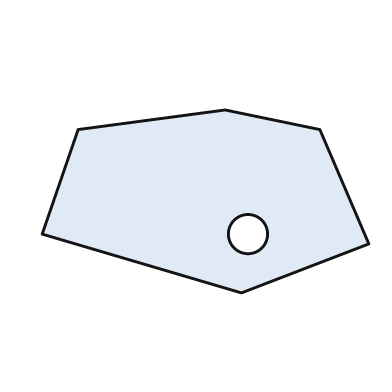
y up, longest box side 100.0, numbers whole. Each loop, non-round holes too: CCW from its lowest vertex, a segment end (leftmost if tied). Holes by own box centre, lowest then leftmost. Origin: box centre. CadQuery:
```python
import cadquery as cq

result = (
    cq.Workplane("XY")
    .moveTo(11.0, -28.0)
    .lineTo(50.0, -13.0)
    .lineTo(35.0, 22.0)
    .lineTo(6.0, 28.0)
    .lineTo(-39.0, 22.0)
    .lineTo(-50.0, -10.0)
    .close()
    .moveTo(13.0, -10.0)
    .circle(6.0)
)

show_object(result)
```